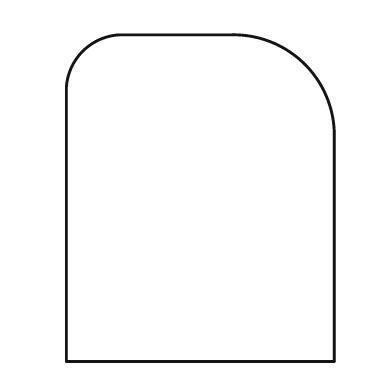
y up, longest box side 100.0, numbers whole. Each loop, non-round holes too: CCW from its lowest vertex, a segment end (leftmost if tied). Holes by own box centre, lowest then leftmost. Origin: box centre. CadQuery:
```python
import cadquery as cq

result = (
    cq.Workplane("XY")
    .moveTo(-41.0, -50.0)
    .lineTo(41.0, -50.0)
    .lineTo(41.0, 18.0)
    .threePointArc((32.0, 41.0), (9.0, 50.0))
    .lineTo(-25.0, 50.0)
    .threePointArc((-36.0, 45.0), (-41.0, 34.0))
    .close()
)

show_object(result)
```